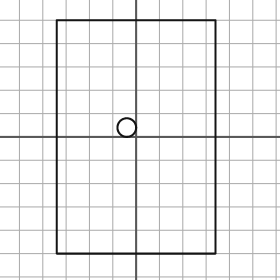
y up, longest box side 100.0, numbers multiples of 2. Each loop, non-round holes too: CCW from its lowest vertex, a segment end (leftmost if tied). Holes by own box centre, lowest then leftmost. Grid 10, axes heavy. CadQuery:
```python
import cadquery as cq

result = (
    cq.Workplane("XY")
    .moveTo(-34.0, -50.0)
    .lineTo(34.0, -50.0)
    .lineTo(34.0, 50.0)
    .lineTo(-34.0, 50.0)
    .close()
    .moveTo(-4.0, 4.0)
    .circle(4.0)
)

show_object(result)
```